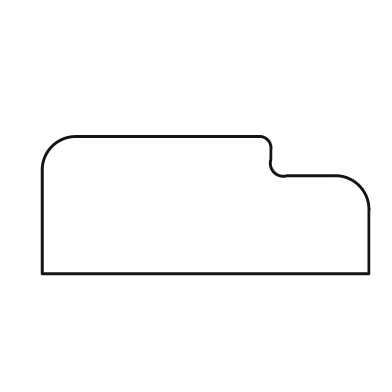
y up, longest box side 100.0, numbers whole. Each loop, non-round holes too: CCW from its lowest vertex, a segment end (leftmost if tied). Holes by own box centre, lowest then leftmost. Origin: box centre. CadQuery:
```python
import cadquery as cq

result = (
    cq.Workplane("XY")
    .moveTo(-50.0, -21.0)
    .lineTo(50.0, -21.0)
    .lineTo(50.0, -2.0)
    .threePointArc((47.0, 6.0), (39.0, 9.0))
    .lineTo(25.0, 9.0)
    .threePointArc((21.0, 10.0), (20.0, 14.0))
    .lineTo(20.0, 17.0)
    .threePointArc((19.0, 20.0), (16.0, 21.0))
    .lineTo(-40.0, 21.0)
    .threePointArc((-47.0, 18.0), (-50.0, 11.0))
    .close()
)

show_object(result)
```